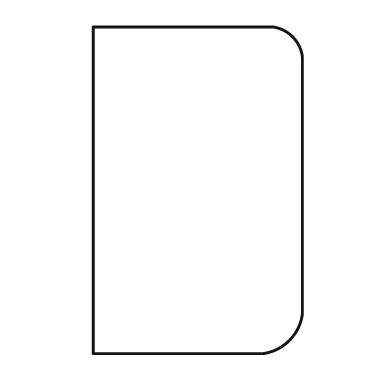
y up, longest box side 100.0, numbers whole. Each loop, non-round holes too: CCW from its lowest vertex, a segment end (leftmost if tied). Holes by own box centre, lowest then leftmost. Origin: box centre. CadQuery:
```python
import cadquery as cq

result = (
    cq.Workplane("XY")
    .moveTo(-32.0, -50.0)
    .lineTo(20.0, -50.0)
    .threePointArc((28.0, -46.0), (32.0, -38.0))
    .lineTo(32.0, 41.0)
    .threePointArc((29.0, 47.0), (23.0, 50.0))
    .lineTo(-32.0, 50.0)
    .close()
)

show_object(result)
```